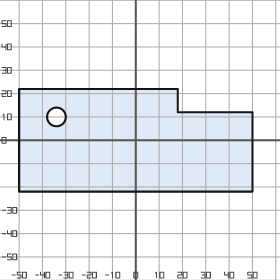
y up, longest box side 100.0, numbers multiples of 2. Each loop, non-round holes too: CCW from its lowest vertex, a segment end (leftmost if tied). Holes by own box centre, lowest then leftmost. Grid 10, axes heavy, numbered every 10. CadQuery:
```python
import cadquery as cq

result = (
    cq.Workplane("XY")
    .moveTo(-50.0, -22.0)
    .lineTo(50.0, -22.0)
    .lineTo(50.0, 12.0)
    .lineTo(18.0, 12.0)
    .lineTo(18.0, 22.0)
    .lineTo(-50.0, 22.0)
    .close()
    .moveTo(-34.0, 10.0)
    .circle(4.0)
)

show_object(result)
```